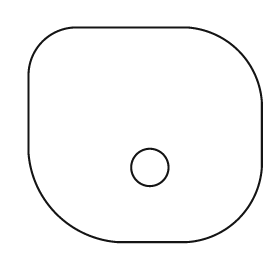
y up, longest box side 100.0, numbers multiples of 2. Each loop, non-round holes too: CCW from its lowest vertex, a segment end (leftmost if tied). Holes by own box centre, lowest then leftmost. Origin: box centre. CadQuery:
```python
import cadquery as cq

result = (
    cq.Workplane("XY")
    .moveTo(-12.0, -46.0)
    .lineTo(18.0, -46.0)
    .threePointArc((40.0, -36.0), (50.0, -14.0))
    .lineTo(50.0, 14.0)
    .threePointArc((40.0, 36.0), (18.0, 46.0))
    .lineTo(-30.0, 46.0)
    .threePointArc((-44.0, 40.0), (-50.0, 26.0))
    .lineTo(-50.0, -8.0)
    .threePointArc((-38.0, -34.0), (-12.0, -46.0))
    .close()
    .moveTo(2.0, -14.0)
    .circle(8.0)
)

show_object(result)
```